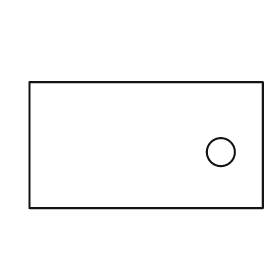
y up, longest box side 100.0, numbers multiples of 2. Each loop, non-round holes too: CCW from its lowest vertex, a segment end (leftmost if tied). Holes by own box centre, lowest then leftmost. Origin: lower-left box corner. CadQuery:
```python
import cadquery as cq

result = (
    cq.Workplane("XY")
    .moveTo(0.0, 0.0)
    .lineTo(100.0, 0.0)
    .lineTo(100.0, 54.0)
    .lineTo(0.0, 54.0)
    .close()
    .moveTo(82.0, 24.0)
    .circle(6.0)
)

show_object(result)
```